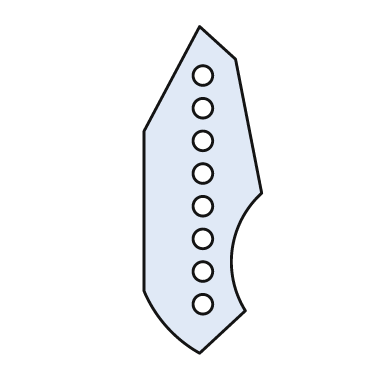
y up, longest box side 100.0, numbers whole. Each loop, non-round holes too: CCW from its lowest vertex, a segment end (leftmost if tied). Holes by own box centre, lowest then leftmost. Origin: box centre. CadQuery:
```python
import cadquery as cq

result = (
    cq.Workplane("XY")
    .moveTo(-1.0, -50.0)
    .lineTo(13.0, -37.0)
    .threePointArc((9.0, -18.0), (18.0, -1.0))
    .lineTo(10.0, 40.0)
    .lineTo(-1.0, 50.0)
    .lineTo(-18.0, 18.0)
    .lineTo(-18.0, -31.0)
    .threePointArc((-11.0, -42.0), (-1.0, -50.0))
    .close()
    .moveTo(0.0, -35.0)
    .circle(3.0)
    .moveTo(0.0, -25.0)
    .circle(3.0)
    .moveTo(0.0, -15.0)
    .circle(3.0)
    .moveTo(0.0, -5.0)
    .circle(3.0)
    .moveTo(0.0, 5.0)
    .circle(3.0)
    .moveTo(0.0, 15.0)
    .circle(3.0)
    .moveTo(0.0, 25.0)
    .circle(3.0)
    .moveTo(0.0, 35.0)
    .circle(3.0)
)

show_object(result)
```